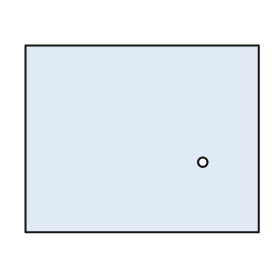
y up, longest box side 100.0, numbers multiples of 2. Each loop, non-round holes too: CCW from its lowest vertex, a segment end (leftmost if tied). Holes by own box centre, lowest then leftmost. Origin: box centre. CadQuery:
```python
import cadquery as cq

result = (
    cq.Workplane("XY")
    .moveTo(-50.0, -40.0)
    .lineTo(50.0, -40.0)
    .lineTo(50.0, 40.0)
    .lineTo(-50.0, 40.0)
    .close()
    .moveTo(26.0, -10.0)
    .circle(2.0)
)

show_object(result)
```